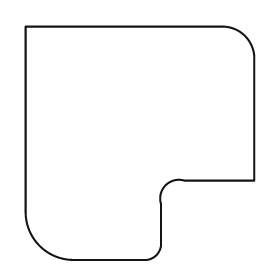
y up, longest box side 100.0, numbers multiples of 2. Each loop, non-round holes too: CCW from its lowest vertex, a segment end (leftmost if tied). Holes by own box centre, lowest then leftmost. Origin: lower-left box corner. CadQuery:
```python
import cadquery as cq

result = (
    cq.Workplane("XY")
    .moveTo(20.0, 0.0)
    .lineTo(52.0, 0.0)
    .threePointArc((56.0, 2.0), (58.0, 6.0))
    .lineTo(58.0, 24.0)
    .threePointArc((60.0, 32.0), (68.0, 34.0))
    .lineTo(98.0, 34.0)
    .lineTo(98.0, 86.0)
    .threePointArc((94.0, 96.0), (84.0, 100.0))
    .lineTo(0.0, 100.0)
    .lineTo(0.0, 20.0)
    .threePointArc((6.0, 6.0), (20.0, 0.0))
    .close()
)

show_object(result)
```